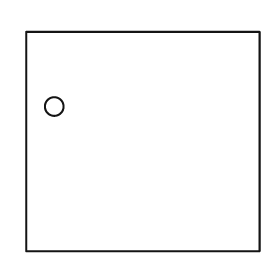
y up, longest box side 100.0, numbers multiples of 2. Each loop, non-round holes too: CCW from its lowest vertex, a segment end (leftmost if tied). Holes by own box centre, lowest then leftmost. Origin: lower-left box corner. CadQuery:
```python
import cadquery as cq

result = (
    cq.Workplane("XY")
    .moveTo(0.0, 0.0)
    .lineTo(100.0, 0.0)
    .lineTo(100.0, 94.0)
    .lineTo(0.0, 94.0)
    .close()
    .moveTo(12.0, 62.0)
    .circle(4.0)
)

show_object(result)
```